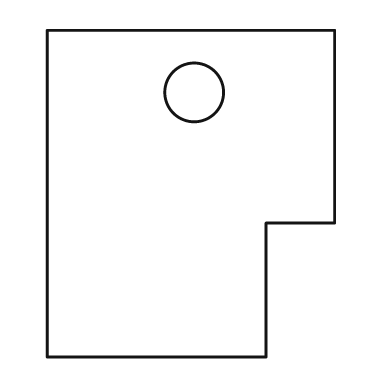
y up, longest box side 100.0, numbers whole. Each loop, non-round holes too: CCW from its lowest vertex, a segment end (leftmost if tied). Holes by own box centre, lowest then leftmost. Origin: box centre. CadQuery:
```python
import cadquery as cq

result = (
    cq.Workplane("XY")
    .moveTo(-44.0, -50.0)
    .lineTo(23.0, -50.0)
    .lineTo(23.0, -9.0)
    .lineTo(44.0, -9.0)
    .lineTo(44.0, 50.0)
    .lineTo(-44.0, 50.0)
    .close()
    .moveTo(1.0, 31.0)
    .circle(9.0)
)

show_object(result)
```